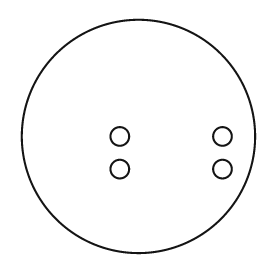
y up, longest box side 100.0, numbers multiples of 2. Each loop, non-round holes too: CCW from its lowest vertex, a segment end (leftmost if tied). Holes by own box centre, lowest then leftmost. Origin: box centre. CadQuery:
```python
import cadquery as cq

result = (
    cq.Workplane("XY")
    .moveTo(0.0, 0.0)
    .circle(50.0)
    .moveTo(-8.0, -14.0)
    .circle(4.0)
    .moveTo(36.0, -14.0)
    .circle(4.0)
    .moveTo(-8.0, 0.0)
    .circle(4.0)
    .moveTo(36.0, 0.0)
    .circle(4.0)
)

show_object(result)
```